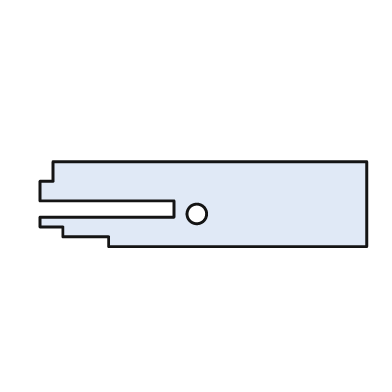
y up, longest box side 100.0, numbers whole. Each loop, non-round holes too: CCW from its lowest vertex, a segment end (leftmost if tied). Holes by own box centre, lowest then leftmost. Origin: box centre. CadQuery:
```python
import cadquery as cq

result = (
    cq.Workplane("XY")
    .moveTo(-29.0, -13.0)
    .lineTo(50.0, -13.0)
    .lineTo(50.0, 13.0)
    .lineTo(-46.0, 13.0)
    .lineTo(-46.0, 7.0)
    .lineTo(-50.0, 7.0)
    .lineTo(-50.0, 1.0)
    .lineTo(-9.0, 1.0)
    .lineTo(-9.0, -4.0)
    .lineTo(-50.0, -4.0)
    .lineTo(-50.0, -7.0)
    .lineTo(-43.0, -7.0)
    .lineTo(-43.0, -10.0)
    .lineTo(-29.0, -10.0)
    .close()
    .moveTo(-2.0, -3.0)
    .circle(3.0)
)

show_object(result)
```